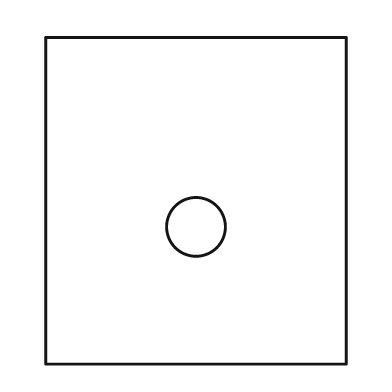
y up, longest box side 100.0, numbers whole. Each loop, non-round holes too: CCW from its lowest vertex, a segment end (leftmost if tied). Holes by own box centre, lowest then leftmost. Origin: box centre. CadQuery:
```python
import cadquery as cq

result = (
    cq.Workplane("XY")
    .moveTo(-46.0, -50.0)
    .lineTo(46.0, -50.0)
    .lineTo(46.0, 50.0)
    .lineTo(-46.0, 50.0)
    .close()
    .moveTo(0.0, -8.0)
    .circle(9.0)
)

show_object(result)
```